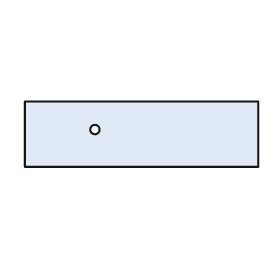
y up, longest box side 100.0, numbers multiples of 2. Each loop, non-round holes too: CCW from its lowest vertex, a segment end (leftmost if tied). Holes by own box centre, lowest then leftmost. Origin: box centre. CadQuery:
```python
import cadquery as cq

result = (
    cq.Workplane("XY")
    .moveTo(-50.0, -14.0)
    .lineTo(50.0, -14.0)
    .lineTo(50.0, 14.0)
    .lineTo(-50.0, 14.0)
    .close()
    .moveTo(-20.0, 2.0)
    .circle(2.0)
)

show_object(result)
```